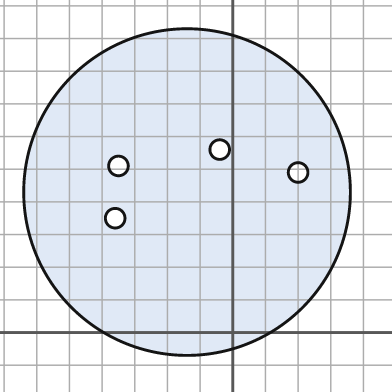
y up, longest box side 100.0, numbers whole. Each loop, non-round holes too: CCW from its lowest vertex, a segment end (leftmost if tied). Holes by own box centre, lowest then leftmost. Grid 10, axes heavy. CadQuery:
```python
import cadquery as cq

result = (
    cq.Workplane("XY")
    .moveTo(-14.0, 43.0)
    .circle(50.0)
    .moveTo(-36.0, 35.0)
    .circle(3.0)
    .moveTo(20.0, 49.0)
    .circle(3.0)
    .moveTo(-35.0, 51.0)
    .circle(3.0)
    .moveTo(-4.0, 56.0)
    .circle(3.0)
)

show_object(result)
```